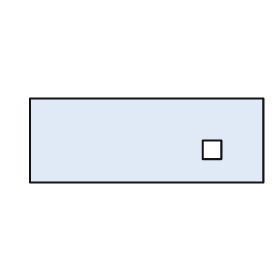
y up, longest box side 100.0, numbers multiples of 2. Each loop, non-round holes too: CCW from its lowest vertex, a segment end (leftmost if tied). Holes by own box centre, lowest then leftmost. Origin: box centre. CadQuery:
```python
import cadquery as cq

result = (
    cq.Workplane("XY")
    .moveTo(-50.0, -18.0)
    .lineTo(50.0, -18.0)
    .lineTo(50.0, 18.0)
    .lineTo(-50.0, 18.0)
    .close()
    .moveTo(24.0, -8.0)
    .lineTo(32.0, -8.0)
    .lineTo(32.0, 0.0)
    .lineTo(24.0, 0.0)
    .close()
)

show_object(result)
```